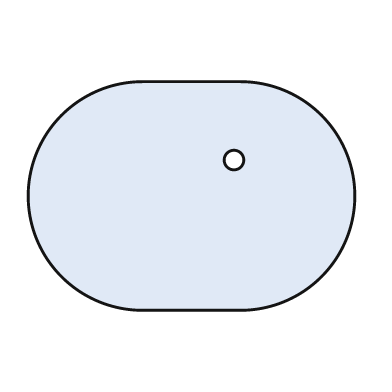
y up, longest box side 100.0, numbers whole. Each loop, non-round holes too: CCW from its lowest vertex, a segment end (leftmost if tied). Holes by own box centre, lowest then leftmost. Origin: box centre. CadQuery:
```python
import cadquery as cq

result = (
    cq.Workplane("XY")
    .moveTo(-15.0, -35.0)
    .lineTo(15.0, -35.0)
    .threePointArc((50.0, 0.0), (15.0, 35.0))
    .lineTo(-15.0, 35.0)
    .threePointArc((-50.0, 0.0), (-15.0, -35.0))
    .close()
    .moveTo(13.0, 11.0)
    .circle(3.0)
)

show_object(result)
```